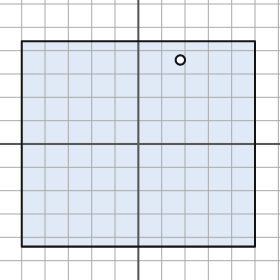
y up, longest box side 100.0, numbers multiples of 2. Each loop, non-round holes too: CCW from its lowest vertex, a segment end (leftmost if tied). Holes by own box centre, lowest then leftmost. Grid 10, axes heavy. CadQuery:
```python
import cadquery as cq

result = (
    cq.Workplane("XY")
    .moveTo(-50.0, -44.0)
    .lineTo(50.0, -44.0)
    .lineTo(50.0, 44.0)
    .lineTo(-50.0, 44.0)
    .close()
    .moveTo(18.0, 36.0)
    .circle(2.0)
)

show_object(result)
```